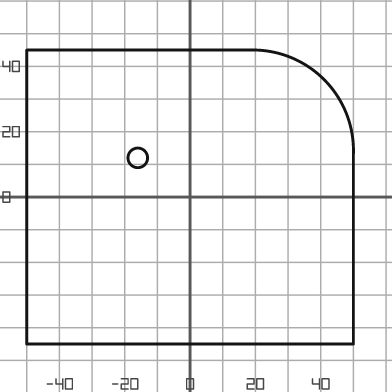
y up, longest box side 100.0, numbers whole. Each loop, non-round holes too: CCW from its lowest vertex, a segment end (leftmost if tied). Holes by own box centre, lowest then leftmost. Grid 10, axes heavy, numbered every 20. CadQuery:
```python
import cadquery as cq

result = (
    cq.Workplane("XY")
    .moveTo(-50.0, -45.0)
    .lineTo(50.0, -45.0)
    .lineTo(50.0, 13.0)
    .threePointArc((41.0, 36.0), (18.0, 45.0))
    .lineTo(-50.0, 45.0)
    .close()
    .moveTo(-16.0, 12.0)
    .circle(3.0)
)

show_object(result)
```